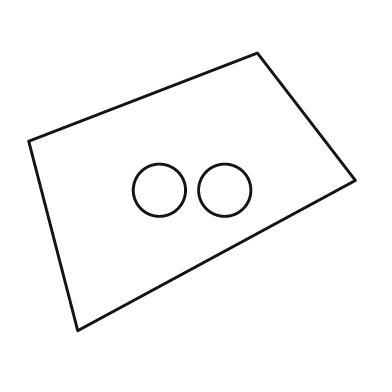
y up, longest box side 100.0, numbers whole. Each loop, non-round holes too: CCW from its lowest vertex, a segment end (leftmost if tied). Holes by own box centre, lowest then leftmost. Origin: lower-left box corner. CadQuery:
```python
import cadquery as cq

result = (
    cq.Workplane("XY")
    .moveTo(15.0, 0.0)
    .lineTo(100.0, 46.0)
    .lineTo(70.0, 85.0)
    .lineTo(0.0, 58.0)
    .close()
    .moveTo(40.0, 43.0)
    .circle(8.0)
    .moveTo(60.0, 43.0)
    .circle(8.0)
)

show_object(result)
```